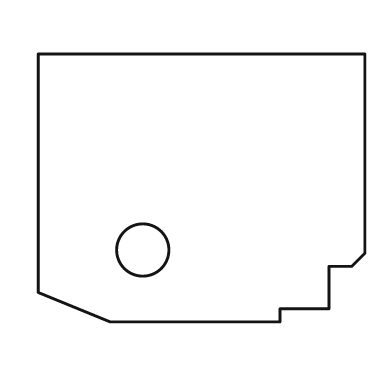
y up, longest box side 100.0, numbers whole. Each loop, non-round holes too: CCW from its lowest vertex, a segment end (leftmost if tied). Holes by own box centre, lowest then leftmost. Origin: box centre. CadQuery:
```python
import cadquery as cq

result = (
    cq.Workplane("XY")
    .moveTo(-28.0, -41.0)
    .lineTo(24.0, -41.0)
    .lineTo(24.0, -37.0)
    .lineTo(39.0, -37.0)
    .lineTo(39.0, -24.0)
    .lineTo(46.0, -24.0)
    .lineTo(50.0, -20.0)
    .lineTo(50.0, 41.0)
    .lineTo(-50.0, 41.0)
    .lineTo(-50.0, -32.0)
    .close()
    .moveTo(-18.0, -19.0)
    .circle(8.0)
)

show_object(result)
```